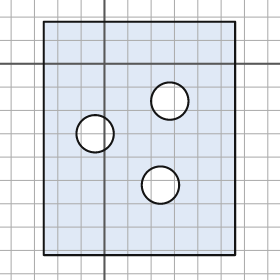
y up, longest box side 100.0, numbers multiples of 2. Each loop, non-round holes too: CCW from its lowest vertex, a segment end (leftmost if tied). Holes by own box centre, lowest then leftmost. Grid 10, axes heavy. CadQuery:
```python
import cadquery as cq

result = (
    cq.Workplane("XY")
    .moveTo(-26.0, -82.0)
    .lineTo(56.0, -82.0)
    .lineTo(56.0, 18.0)
    .lineTo(-26.0, 18.0)
    .close()
    .moveTo(24.0, -52.0)
    .circle(8.0)
    .moveTo(-4.0, -30.0)
    .circle(8.0)
    .moveTo(28.0, -16.0)
    .circle(8.0)
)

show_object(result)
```